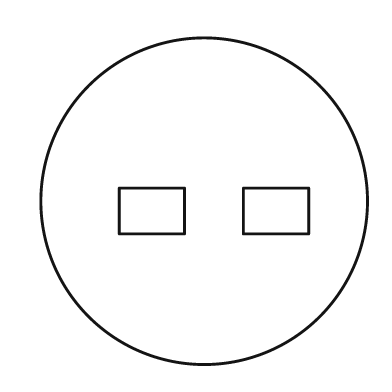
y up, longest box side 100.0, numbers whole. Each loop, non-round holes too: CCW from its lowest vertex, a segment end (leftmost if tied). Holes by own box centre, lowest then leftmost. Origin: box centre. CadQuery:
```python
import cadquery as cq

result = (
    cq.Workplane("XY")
    .moveTo(0.0, 0.0)
    .circle(50.0)
    .moveTo(-26.0, -10.0)
    .lineTo(-6.0, -10.0)
    .lineTo(-6.0, 4.0)
    .lineTo(-26.0, 4.0)
    .close()
    .moveTo(12.0, -10.0)
    .lineTo(32.0, -10.0)
    .lineTo(32.0, 4.0)
    .lineTo(12.0, 4.0)
    .close()
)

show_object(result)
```